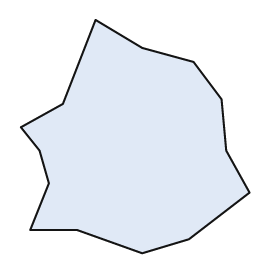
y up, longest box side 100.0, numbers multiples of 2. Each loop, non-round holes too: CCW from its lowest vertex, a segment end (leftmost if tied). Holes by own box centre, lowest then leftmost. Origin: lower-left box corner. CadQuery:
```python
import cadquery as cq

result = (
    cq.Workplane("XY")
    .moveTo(52.0, 0.0)
    .lineTo(72.0, 6.0)
    .lineTo(98.0, 26.0)
    .lineTo(88.0, 44.0)
    .lineTo(86.0, 66.0)
    .lineTo(74.0, 82.0)
    .lineTo(52.0, 88.0)
    .lineTo(32.0, 100.0)
    .lineTo(18.0, 64.0)
    .lineTo(0.0, 54.0)
    .lineTo(8.0, 44.0)
    .lineTo(12.0, 30.0)
    .lineTo(4.0, 10.0)
    .lineTo(24.0, 10.0)
    .close()
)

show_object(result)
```